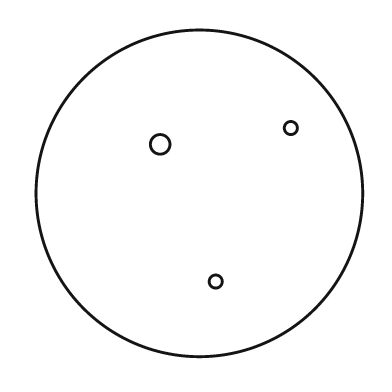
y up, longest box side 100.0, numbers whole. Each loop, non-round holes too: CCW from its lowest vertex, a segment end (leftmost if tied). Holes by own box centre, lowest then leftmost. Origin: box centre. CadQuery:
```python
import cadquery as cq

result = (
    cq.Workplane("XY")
    .moveTo(0.0, 0.0)
    .circle(50.0)
    .moveTo(5.0, -27.0)
    .circle(2.0)
    .moveTo(-12.0, 15.0)
    .circle(3.0)
    .moveTo(28.0, 20.0)
    .circle(2.0)
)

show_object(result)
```